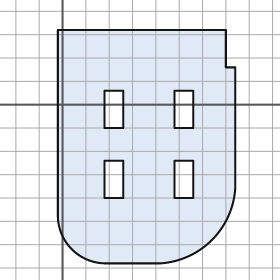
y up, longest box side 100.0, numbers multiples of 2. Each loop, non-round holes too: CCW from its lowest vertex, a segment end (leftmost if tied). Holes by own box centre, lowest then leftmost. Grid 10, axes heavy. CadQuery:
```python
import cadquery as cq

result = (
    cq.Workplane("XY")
    .moveTo(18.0, -68.0)
    .lineTo(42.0, -68.0)
    .threePointArc((64.0, -58.0), (74.0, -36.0))
    .lineTo(74.0, 16.0)
    .lineTo(70.0, 16.0)
    .lineTo(70.0, 32.0)
    .lineTo(-2.0, 32.0)
    .lineTo(-2.0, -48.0)
    .threePointArc((4.0, -62.0), (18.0, -68.0))
    .close()
    .moveTo(18.0, -40.0)
    .lineTo(26.0, -40.0)
    .lineTo(26.0, -24.0)
    .lineTo(18.0, -24.0)
    .close()
    .moveTo(48.0, -40.0)
    .lineTo(56.0, -40.0)
    .lineTo(56.0, -24.0)
    .lineTo(48.0, -24.0)
    .close()
    .moveTo(18.0, -10.0)
    .lineTo(26.0, -10.0)
    .lineTo(26.0, 6.0)
    .lineTo(18.0, 6.0)
    .close()
    .moveTo(48.0, -10.0)
    .lineTo(56.0, -10.0)
    .lineTo(56.0, 6.0)
    .lineTo(48.0, 6.0)
    .close()
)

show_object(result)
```